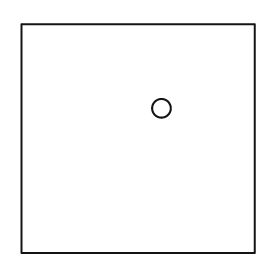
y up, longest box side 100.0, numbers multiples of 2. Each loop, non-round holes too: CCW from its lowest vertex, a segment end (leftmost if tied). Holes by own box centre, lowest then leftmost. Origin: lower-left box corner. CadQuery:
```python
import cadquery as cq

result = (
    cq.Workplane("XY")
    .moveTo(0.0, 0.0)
    .lineTo(100.0, 0.0)
    .lineTo(100.0, 98.0)
    .lineTo(0.0, 98.0)
    .close()
    .moveTo(60.0, 62.0)
    .circle(4.0)
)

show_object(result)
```